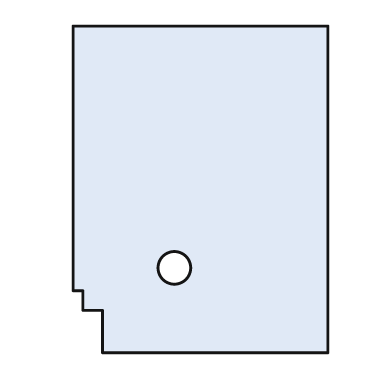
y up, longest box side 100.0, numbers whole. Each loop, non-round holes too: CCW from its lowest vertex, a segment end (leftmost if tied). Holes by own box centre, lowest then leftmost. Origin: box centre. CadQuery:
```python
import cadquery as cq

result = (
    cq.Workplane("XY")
    .moveTo(-30.0, -50.0)
    .lineTo(39.0, -50.0)
    .lineTo(39.0, 50.0)
    .lineTo(-39.0, 50.0)
    .lineTo(-39.0, -31.0)
    .lineTo(-36.0, -31.0)
    .lineTo(-36.0, -37.0)
    .lineTo(-30.0, -37.0)
    .close()
    .moveTo(-8.0, -24.0)
    .circle(5.0)
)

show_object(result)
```